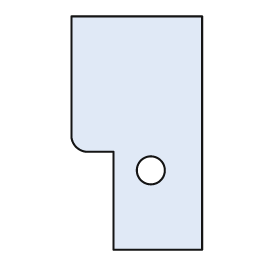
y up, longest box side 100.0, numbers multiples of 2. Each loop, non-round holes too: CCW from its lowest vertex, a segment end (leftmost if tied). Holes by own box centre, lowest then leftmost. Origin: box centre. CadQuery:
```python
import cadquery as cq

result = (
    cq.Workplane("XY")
    .moveTo(-10.0, -50.0)
    .lineTo(28.0, -50.0)
    .lineTo(28.0, 50.0)
    .lineTo(-28.0, 50.0)
    .lineTo(-28.0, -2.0)
    .threePointArc((-26.0, -6.0), (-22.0, -8.0))
    .lineTo(-10.0, -8.0)
    .close()
    .moveTo(6.0, -16.0)
    .circle(6.0)
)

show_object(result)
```